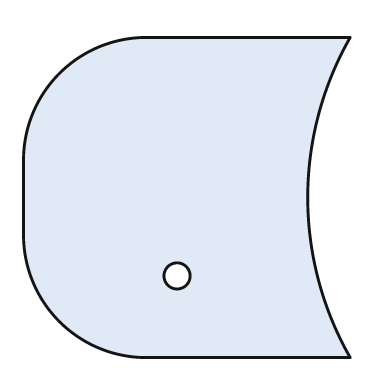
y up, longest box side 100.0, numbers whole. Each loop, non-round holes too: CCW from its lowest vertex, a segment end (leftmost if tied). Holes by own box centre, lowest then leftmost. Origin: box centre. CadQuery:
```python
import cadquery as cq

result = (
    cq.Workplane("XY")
    .moveTo(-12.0, -49.0)
    .lineTo(50.0, -49.0)
    .threePointArc((37.0, 0.0), (50.0, 49.0))
    .lineTo(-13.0, 49.0)
    .threePointArc((-39.0, 38.0), (-50.0, 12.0))
    .lineTo(-50.0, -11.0)
    .threePointArc((-39.0, -38.0), (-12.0, -49.0))
    .close()
    .moveTo(-3.0, -24.0)
    .circle(4.0)
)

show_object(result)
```